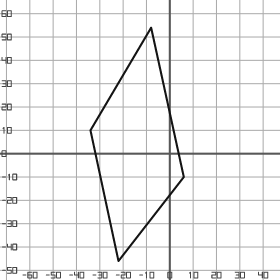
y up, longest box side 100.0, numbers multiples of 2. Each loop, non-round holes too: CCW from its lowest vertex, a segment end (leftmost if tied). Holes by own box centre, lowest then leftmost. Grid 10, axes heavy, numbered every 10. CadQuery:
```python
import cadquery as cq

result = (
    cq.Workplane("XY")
    .moveTo(-22.0, -46.0)
    .lineTo(6.0, -10.0)
    .lineTo(-8.0, 54.0)
    .lineTo(-34.0, 10.0)
    .close()
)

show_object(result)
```